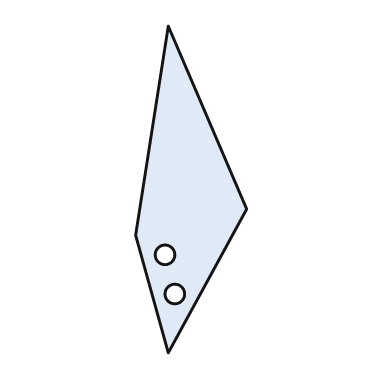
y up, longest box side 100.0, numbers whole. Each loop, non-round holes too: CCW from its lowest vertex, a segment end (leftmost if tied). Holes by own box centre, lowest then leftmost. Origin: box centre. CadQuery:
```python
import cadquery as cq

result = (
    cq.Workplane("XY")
    .moveTo(-7.0, -50.0)
    .lineTo(17.0, -6.0)
    .lineTo(-7.0, 50.0)
    .lineTo(-17.0, -14.0)
    .close()
    .moveTo(-5.0, -32.0)
    .circle(3.0)
    .moveTo(-8.0, -20.0)
    .circle(3.0)
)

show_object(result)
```